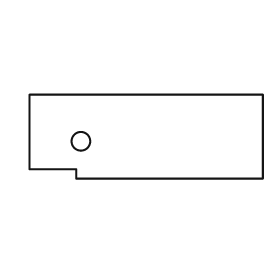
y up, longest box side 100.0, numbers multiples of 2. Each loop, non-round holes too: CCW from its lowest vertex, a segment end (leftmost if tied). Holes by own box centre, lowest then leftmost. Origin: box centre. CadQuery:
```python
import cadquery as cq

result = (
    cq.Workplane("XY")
    .moveTo(-30.0, -18.0)
    .lineTo(50.0, -18.0)
    .lineTo(50.0, 18.0)
    .lineTo(-50.0, 18.0)
    .lineTo(-50.0, -14.0)
    .lineTo(-30.0, -14.0)
    .close()
    .moveTo(-28.0, -2.0)
    .circle(4.0)
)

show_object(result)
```